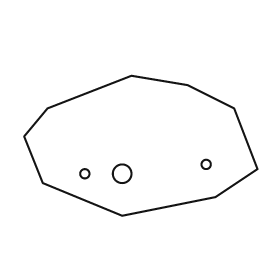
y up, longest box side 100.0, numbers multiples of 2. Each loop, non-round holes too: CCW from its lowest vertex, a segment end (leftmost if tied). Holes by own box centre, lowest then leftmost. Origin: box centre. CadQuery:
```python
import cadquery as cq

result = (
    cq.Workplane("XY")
    .moveTo(-8.0, -30.0)
    .lineTo(32.0, -22.0)
    .lineTo(50.0, -10.0)
    .lineTo(40.0, 16.0)
    .lineTo(20.0, 26.0)
    .lineTo(-4.0, 30.0)
    .lineTo(-40.0, 16.0)
    .lineTo(-50.0, 4.0)
    .lineTo(-42.0, -16.0)
    .close()
    .moveTo(-24.0, -12.0)
    .circle(2.0)
    .moveTo(-8.0, -12.0)
    .circle(4.0)
    .moveTo(28.0, -8.0)
    .circle(2.0)
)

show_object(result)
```